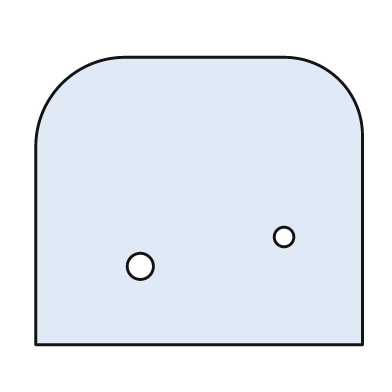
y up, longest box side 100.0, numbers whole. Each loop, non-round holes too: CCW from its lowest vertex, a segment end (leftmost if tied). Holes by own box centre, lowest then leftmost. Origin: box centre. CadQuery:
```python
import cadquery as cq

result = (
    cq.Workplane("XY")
    .moveTo(-50.0, -44.0)
    .lineTo(50.0, -44.0)
    .lineTo(50.0, 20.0)
    .threePointArc((43.0, 37.0), (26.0, 44.0))
    .lineTo(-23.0, 44.0)
    .threePointArc((-42.0, 36.0), (-50.0, 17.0))
    .close()
    .moveTo(-18.0, -20.0)
    .circle(4.0)
    .moveTo(26.0, -11.0)
    .circle(3.0)
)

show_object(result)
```